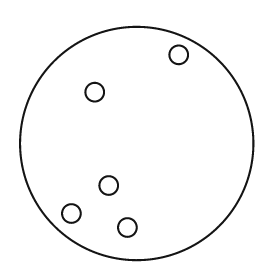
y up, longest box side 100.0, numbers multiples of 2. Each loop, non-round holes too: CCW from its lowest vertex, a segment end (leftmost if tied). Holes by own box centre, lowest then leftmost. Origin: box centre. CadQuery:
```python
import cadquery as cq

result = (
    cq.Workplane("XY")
    .moveTo(0.0, 0.0)
    .circle(50.0)
    .moveTo(-4.0, -36.0)
    .circle(4.0)
    .moveTo(-28.0, -30.0)
    .circle(4.0)
    .moveTo(-12.0, -18.0)
    .circle(4.0)
    .moveTo(-18.0, 22.0)
    .circle(4.0)
    .moveTo(18.0, 38.0)
    .circle(4.0)
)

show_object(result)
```